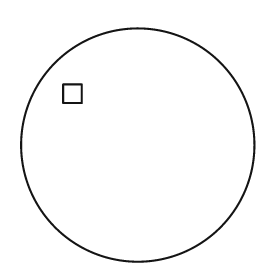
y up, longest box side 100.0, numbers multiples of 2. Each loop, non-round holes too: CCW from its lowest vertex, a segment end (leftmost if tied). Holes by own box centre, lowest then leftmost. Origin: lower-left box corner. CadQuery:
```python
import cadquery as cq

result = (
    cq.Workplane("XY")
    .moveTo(50.0, 50.0)
    .circle(50.0)
    .moveTo(18.0, 68.0)
    .lineTo(26.0, 68.0)
    .lineTo(26.0, 76.0)
    .lineTo(18.0, 76.0)
    .close()
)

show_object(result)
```